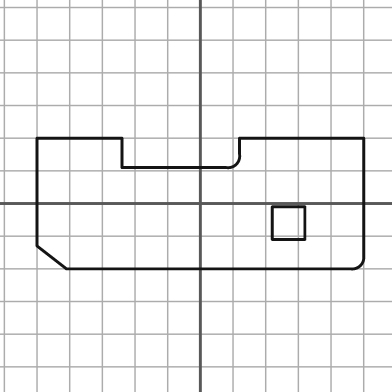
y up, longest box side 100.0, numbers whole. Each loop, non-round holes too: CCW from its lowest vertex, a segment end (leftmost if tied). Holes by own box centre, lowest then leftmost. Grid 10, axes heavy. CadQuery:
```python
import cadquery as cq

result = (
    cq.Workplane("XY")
    .moveTo(-41.0, -20.0)
    .lineTo(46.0, -20.0)
    .threePointArc((49.0, -19.0), (50.0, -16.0))
    .lineTo(50.0, 20.0)
    .lineTo(12.0, 20.0)
    .lineTo(12.0, 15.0)
    .threePointArc((11.0, 12.0), (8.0, 11.0))
    .lineTo(-24.0, 11.0)
    .lineTo(-24.0, 20.0)
    .lineTo(-50.0, 20.0)
    .lineTo(-50.0, -13.0)
    .close()
    .moveTo(22.0, -11.0)
    .lineTo(32.0, -11.0)
    .lineTo(32.0, -1.0)
    .lineTo(22.0, -1.0)
    .close()
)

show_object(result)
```